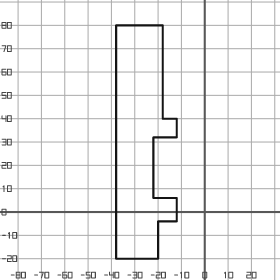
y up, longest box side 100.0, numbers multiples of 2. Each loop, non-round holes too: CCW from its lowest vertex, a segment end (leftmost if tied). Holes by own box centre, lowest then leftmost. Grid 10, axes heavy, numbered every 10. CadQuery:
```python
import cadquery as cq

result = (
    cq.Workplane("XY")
    .moveTo(-38.0, -20.0)
    .lineTo(-20.0, -20.0)
    .lineTo(-20.0, -4.0)
    .lineTo(-12.0, -4.0)
    .lineTo(-12.0, 6.0)
    .lineTo(-22.0, 6.0)
    .lineTo(-22.0, 32.0)
    .lineTo(-12.0, 32.0)
    .lineTo(-12.0, 40.0)
    .lineTo(-18.0, 40.0)
    .lineTo(-18.0, 80.0)
    .lineTo(-38.0, 80.0)
    .close()
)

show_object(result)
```